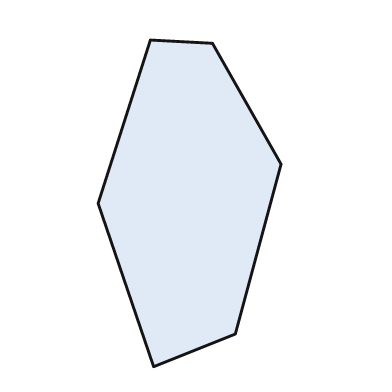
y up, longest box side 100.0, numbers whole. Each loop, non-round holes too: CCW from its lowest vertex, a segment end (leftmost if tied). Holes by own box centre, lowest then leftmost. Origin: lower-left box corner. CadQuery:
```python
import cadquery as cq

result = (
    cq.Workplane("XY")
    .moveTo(17.0, 0.0)
    .lineTo(42.0, 10.0)
    .lineTo(56.0, 62.0)
    .lineTo(35.0, 99.0)
    .lineTo(16.0, 100.0)
    .lineTo(0.0, 50.0)
    .close()
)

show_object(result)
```